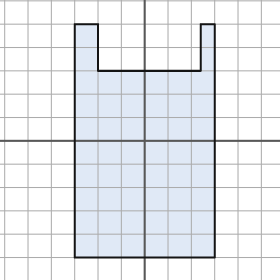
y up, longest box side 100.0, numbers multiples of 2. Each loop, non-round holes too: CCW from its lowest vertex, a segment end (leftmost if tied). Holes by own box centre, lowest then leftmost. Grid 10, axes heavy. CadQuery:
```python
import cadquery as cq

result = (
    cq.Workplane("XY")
    .moveTo(-30.0, -50.0)
    .lineTo(30.0, -50.0)
    .lineTo(30.0, 50.0)
    .lineTo(24.0, 50.0)
    .lineTo(24.0, 30.0)
    .lineTo(-20.0, 30.0)
    .lineTo(-20.0, 50.0)
    .lineTo(-30.0, 50.0)
    .close()
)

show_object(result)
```